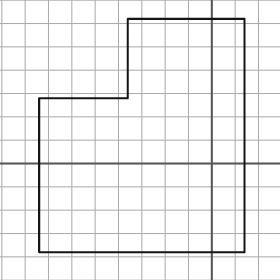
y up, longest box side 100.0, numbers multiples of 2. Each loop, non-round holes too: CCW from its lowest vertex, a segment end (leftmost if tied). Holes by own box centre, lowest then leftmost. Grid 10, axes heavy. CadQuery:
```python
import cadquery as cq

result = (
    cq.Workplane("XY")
    .moveTo(-74.0, -38.0)
    .lineTo(14.0, -38.0)
    .lineTo(14.0, 62.0)
    .lineTo(-36.0, 62.0)
    .lineTo(-36.0, 28.0)
    .lineTo(-74.0, 28.0)
    .close()
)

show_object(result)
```